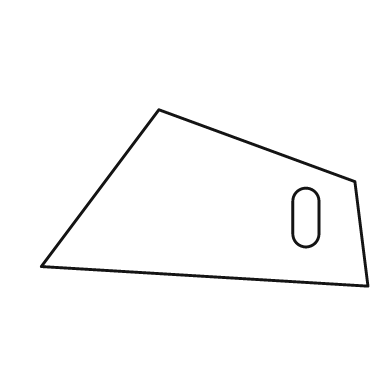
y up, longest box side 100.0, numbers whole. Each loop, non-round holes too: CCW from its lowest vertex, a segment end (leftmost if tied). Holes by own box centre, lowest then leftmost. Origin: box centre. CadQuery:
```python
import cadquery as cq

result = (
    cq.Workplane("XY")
    .moveTo(50.0, -27.0)
    .lineTo(46.0, 5.0)
    .lineTo(-14.0, 27.0)
    .lineTo(-50.0, -21.0)
    .close()
    .moveTo(27.0, -11.0)
    .threePointArc((31.0, -15.0), (35.0, -11.0))
    .lineTo(35.0, -1.0)
    .threePointArc((31.0, 3.0), (27.0, -1.0))
    .close()
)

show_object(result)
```